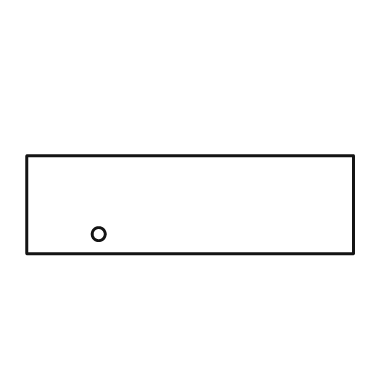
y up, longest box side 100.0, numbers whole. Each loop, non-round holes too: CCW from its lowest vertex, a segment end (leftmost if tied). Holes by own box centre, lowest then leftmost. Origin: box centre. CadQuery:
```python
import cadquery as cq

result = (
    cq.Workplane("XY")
    .moveTo(-50.0, -15.0)
    .lineTo(50.0, -15.0)
    .lineTo(50.0, 15.0)
    .lineTo(-50.0, 15.0)
    .close()
    .moveTo(-28.0, -9.0)
    .circle(2.0)
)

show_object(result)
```